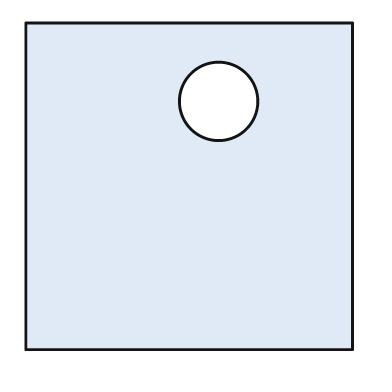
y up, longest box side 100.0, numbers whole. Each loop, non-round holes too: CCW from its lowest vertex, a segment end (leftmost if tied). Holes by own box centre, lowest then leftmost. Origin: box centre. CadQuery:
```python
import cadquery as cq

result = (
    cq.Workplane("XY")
    .moveTo(-50.0, -50.0)
    .lineTo(50.0, -50.0)
    .lineTo(50.0, 50.0)
    .lineTo(-50.0, 50.0)
    .close()
    .moveTo(9.0, 26.0)
    .circle(12.0)
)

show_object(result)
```